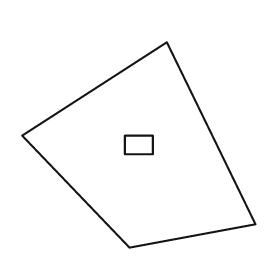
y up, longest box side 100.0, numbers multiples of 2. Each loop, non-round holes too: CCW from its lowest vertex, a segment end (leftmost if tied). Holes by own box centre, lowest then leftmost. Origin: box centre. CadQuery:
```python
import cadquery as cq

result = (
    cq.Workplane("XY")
    .moveTo(-4.0, -44.0)
    .lineTo(50.0, -34.0)
    .lineTo(12.0, 44.0)
    .lineTo(-50.0, 4.0)
    .close()
    .moveTo(-6.0, -4.0)
    .lineTo(6.0, -4.0)
    .lineTo(6.0, 4.0)
    .lineTo(-6.0, 4.0)
    .close()
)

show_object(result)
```